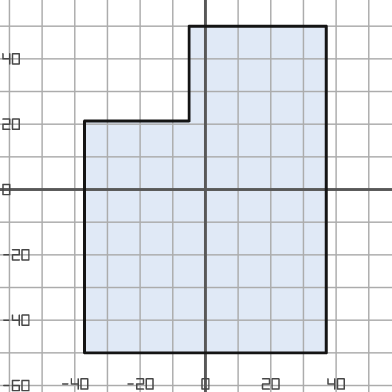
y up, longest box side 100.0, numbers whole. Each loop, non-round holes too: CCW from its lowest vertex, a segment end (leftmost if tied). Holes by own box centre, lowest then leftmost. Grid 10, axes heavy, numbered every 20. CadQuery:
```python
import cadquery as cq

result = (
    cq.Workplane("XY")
    .moveTo(-37.0, -50.0)
    .lineTo(37.0, -50.0)
    .lineTo(37.0, 50.0)
    .lineTo(-5.0, 50.0)
    .lineTo(-5.0, 21.0)
    .lineTo(-37.0, 21.0)
    .close()
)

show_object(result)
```